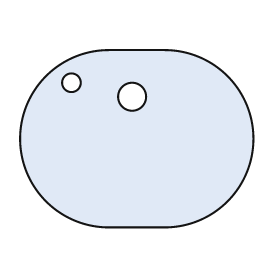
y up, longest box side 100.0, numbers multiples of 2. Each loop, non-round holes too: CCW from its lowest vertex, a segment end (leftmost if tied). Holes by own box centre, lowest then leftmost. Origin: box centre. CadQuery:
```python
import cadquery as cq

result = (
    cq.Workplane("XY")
    .moveTo(-12.0, -38.0)
    .lineTo(12.0, -38.0)
    .threePointArc((50.0, 0.0), (12.0, 38.0))
    .lineTo(-12.0, 38.0)
    .threePointArc((-50.0, 0.0), (-12.0, -38.0))
    .close()
    .moveTo(-2.0, 18.0)
    .circle(6.0)
    .moveTo(-28.0, 24.0)
    .circle(4.0)
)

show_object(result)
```